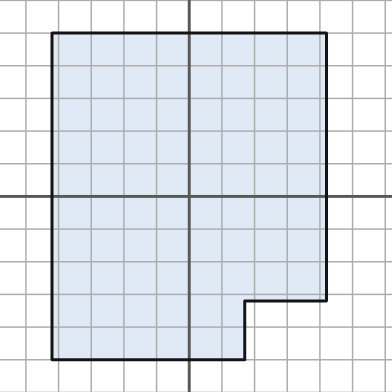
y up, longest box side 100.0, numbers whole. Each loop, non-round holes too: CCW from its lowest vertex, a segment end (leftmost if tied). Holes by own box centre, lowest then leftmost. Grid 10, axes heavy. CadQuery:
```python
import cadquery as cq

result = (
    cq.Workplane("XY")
    .moveTo(-42.0, -50.0)
    .lineTo(17.0, -50.0)
    .lineTo(17.0, -32.0)
    .lineTo(42.0, -32.0)
    .lineTo(42.0, 50.0)
    .lineTo(-42.0, 50.0)
    .close()
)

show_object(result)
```